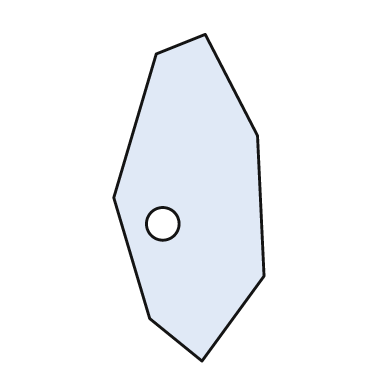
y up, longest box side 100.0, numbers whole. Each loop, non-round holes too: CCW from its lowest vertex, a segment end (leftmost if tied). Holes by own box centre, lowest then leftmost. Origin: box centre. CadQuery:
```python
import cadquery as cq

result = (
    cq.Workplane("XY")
    .moveTo(4.0, -50.0)
    .lineTo(23.0, -24.0)
    .lineTo(21.0, 19.0)
    .lineTo(5.0, 50.0)
    .lineTo(-10.0, 44.0)
    .lineTo(-23.0, 0.0)
    .lineTo(-12.0, -37.0)
    .close()
    .moveTo(-8.0, -8.0)
    .circle(5.0)
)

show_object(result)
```